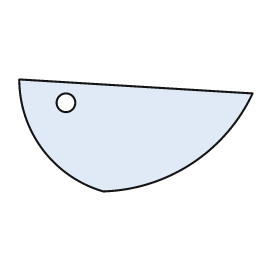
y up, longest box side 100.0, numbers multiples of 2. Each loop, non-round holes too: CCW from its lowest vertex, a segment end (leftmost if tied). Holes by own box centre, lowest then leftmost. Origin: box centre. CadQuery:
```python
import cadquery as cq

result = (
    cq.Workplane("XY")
    .moveTo(-14.0, -24.0)
    .threePointArc((24.0, -12.0), (50.0, 18.0))
    .lineTo(-50.0, 24.0)
    .threePointArc((-40.0, -6.0), (-14.0, -24.0))
    .close()
    .moveTo(-30.0, 14.0)
    .circle(4.0)
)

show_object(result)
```